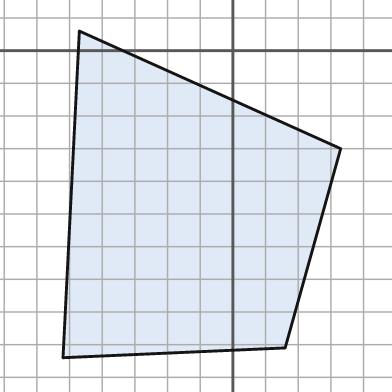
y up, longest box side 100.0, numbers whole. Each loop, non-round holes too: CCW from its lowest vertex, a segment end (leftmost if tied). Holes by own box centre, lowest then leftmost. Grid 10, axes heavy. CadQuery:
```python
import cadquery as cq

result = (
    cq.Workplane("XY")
    .moveTo(-52.0, -94.0)
    .lineTo(16.0, -91.0)
    .lineTo(33.0, -30.0)
    .lineTo(-47.0, 6.0)
    .close()
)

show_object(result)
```